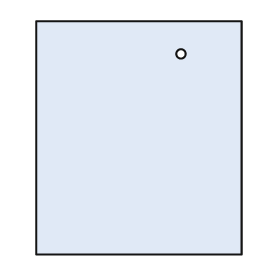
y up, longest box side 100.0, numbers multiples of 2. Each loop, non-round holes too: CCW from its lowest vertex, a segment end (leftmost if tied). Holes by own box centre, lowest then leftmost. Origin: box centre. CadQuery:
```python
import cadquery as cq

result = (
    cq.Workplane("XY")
    .moveTo(-44.0, -50.0)
    .lineTo(44.0, -50.0)
    .lineTo(44.0, 50.0)
    .lineTo(-44.0, 50.0)
    .close()
    .moveTo(18.0, 36.0)
    .circle(2.0)
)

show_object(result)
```